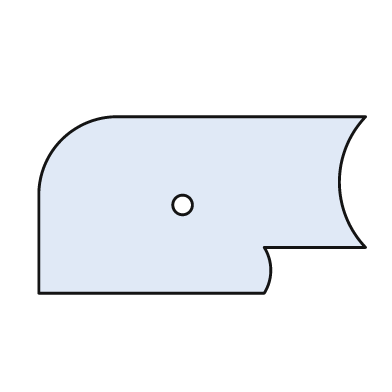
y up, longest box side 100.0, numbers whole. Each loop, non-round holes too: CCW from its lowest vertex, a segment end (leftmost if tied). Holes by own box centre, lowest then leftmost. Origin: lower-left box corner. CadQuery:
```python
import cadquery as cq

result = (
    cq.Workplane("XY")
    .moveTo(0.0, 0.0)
    .lineTo(69.0, 0.0)
    .threePointArc((71.0, 7.0), (69.0, 14.0))
    .lineTo(100.0, 14.0)
    .threePointArc((92.0, 34.0), (100.0, 54.0))
    .lineTo(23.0, 54.0)
    .threePointArc((7.0, 47.0), (0.0, 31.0))
    .close()
    .moveTo(44.0, 27.0)
    .circle(3.0)
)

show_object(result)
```